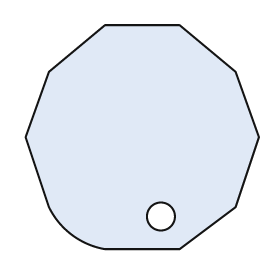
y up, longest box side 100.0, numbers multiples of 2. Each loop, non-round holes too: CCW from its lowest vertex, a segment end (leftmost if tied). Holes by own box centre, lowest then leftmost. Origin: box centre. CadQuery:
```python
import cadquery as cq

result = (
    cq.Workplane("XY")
    .moveTo(-16.0, -48.0)
    .lineTo(16.0, -48.0)
    .lineTo(40.0, -30.0)
    .lineTo(50.0, 0.0)
    .lineTo(40.0, 28.0)
    .lineTo(16.0, 48.0)
    .lineTo(-16.0, 48.0)
    .lineTo(-40.0, 28.0)
    .lineTo(-50.0, 0.0)
    .lineTo(-40.0, -30.0)
    .threePointArc((-30.0, -42.0), (-16.0, -48.0))
    .close()
    .moveTo(8.0, -34.0)
    .circle(6.0)
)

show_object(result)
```